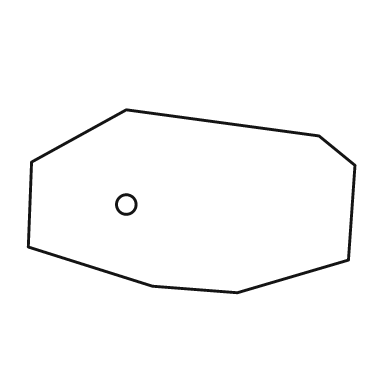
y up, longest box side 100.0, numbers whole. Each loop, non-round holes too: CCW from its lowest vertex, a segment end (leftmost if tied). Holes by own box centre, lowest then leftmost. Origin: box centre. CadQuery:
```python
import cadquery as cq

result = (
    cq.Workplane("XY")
    .moveTo(14.0, -28.0)
    .lineTo(48.0, -18.0)
    .lineTo(50.0, 11.0)
    .lineTo(39.0, 20.0)
    .lineTo(-20.0, 28.0)
    .lineTo(-49.0, 12.0)
    .lineTo(-50.0, -14.0)
    .lineTo(-12.0, -26.0)
    .close()
    .moveTo(-20.0, -1.0)
    .circle(3.0)
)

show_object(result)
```